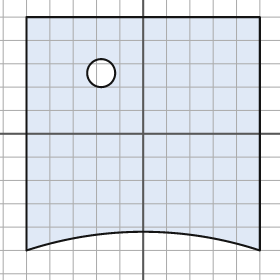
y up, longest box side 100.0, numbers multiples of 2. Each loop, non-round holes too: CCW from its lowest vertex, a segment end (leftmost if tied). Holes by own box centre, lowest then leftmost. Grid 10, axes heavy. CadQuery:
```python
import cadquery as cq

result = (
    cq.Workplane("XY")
    .moveTo(-50.0, -50.0)
    .threePointArc((0.0, -42.0), (50.0, -50.0))
    .lineTo(50.0, 50.0)
    .lineTo(-50.0, 50.0)
    .close()
    .moveTo(-18.0, 26.0)
    .circle(6.0)
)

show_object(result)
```